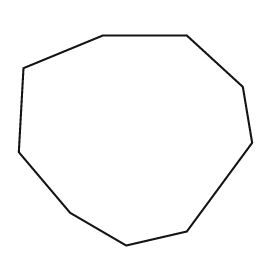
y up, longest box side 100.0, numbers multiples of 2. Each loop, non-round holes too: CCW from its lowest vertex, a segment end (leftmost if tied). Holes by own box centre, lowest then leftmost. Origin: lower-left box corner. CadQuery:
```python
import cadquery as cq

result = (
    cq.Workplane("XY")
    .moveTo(46.0, 0.0)
    .lineTo(72.0, 6.0)
    .lineTo(100.0, 44.0)
    .lineTo(96.0, 68.0)
    .lineTo(72.0, 90.0)
    .lineTo(36.0, 90.0)
    .lineTo(2.0, 76.0)
    .lineTo(0.0, 40.0)
    .lineTo(22.0, 14.0)
    .close()
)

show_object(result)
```